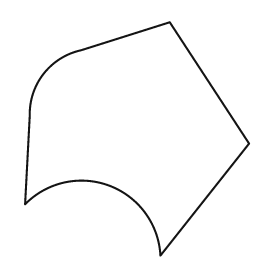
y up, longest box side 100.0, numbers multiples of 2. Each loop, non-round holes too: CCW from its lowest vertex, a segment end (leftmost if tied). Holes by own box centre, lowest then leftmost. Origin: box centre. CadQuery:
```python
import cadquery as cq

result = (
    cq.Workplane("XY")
    .moveTo(10.0, -50.0)
    .lineTo(48.0, -2.0)
    .lineTo(14.0, 50.0)
    .lineTo(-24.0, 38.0)
    .threePointArc((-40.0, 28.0), (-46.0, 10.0))
    .lineTo(-48.0, -28.0)
    .threePointArc((-12.0, -20.0), (10.0, -50.0))
    .close()
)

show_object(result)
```